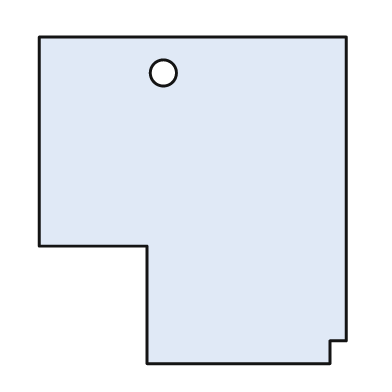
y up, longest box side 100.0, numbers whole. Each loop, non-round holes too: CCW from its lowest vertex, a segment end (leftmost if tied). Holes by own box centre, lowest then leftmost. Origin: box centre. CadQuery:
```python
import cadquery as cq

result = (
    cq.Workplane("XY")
    .moveTo(-14.0, -50.0)
    .lineTo(42.0, -50.0)
    .lineTo(42.0, -43.0)
    .lineTo(47.0, -43.0)
    .lineTo(47.0, 50.0)
    .lineTo(-47.0, 50.0)
    .lineTo(-47.0, -14.0)
    .lineTo(-14.0, -14.0)
    .close()
    .moveTo(-9.0, 39.0)
    .circle(4.0)
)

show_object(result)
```